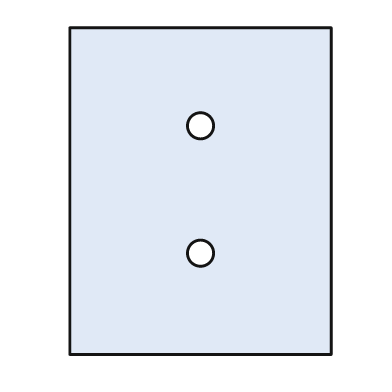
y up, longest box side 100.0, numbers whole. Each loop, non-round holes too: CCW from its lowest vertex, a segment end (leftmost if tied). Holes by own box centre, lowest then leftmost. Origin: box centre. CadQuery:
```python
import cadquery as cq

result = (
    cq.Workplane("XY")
    .moveTo(-40.0, -50.0)
    .lineTo(40.0, -50.0)
    .lineTo(40.0, 50.0)
    .lineTo(-40.0, 50.0)
    .close()
    .moveTo(0.0, -19.0)
    .circle(4.0)
    .moveTo(0.0, 20.0)
    .circle(4.0)
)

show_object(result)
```